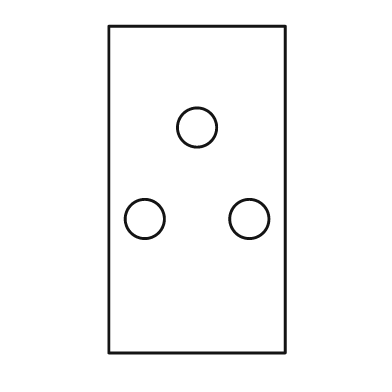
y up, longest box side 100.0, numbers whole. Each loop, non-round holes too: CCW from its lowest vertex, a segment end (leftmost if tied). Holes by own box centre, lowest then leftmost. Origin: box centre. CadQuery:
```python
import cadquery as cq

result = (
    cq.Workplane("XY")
    .moveTo(-27.0, -50.0)
    .lineTo(27.0, -50.0)
    .lineTo(27.0, 50.0)
    .lineTo(-27.0, 50.0)
    .close()
    .moveTo(-16.0, -9.0)
    .circle(6.0)
    .moveTo(16.0, -9.0)
    .circle(6.0)
    .moveTo(0.0, 19.0)
    .circle(6.0)
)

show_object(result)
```